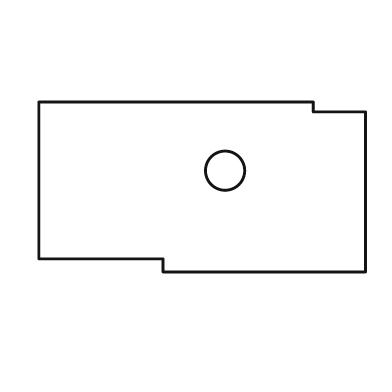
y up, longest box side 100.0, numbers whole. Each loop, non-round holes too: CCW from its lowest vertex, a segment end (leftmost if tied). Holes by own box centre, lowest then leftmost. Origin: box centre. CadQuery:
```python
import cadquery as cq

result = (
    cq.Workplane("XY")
    .moveTo(-12.0, -26.0)
    .lineTo(50.0, -26.0)
    .lineTo(50.0, 23.0)
    .lineTo(34.0, 23.0)
    .lineTo(34.0, 26.0)
    .lineTo(-50.0, 26.0)
    .lineTo(-50.0, -22.0)
    .lineTo(-12.0, -22.0)
    .close()
    .moveTo(7.0, 5.0)
    .circle(6.0)
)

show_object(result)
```